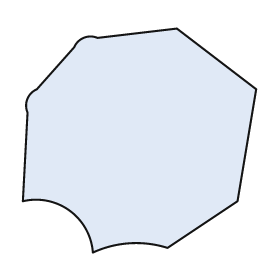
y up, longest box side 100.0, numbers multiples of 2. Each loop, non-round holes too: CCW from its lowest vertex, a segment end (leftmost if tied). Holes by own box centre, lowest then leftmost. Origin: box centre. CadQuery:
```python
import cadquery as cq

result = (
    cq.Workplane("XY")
    .moveTo(-20.0, -48.0)
    .threePointArc((-4.0, -44.0), (12.0, -46.0))
    .lineTo(42.0, -26.0)
    .lineTo(50.0, 22.0)
    .lineTo(16.0, 48.0)
    .lineTo(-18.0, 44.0)
    .threePointArc((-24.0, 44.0), (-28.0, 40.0))
    .lineTo(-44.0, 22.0)
    .threePointArc((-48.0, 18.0), (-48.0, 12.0))
    .lineTo(-50.0, -26.0)
    .threePointArc((-30.0, -30.0), (-20.0, -48.0))
    .close()
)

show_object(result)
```